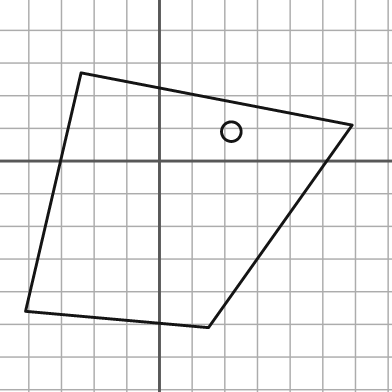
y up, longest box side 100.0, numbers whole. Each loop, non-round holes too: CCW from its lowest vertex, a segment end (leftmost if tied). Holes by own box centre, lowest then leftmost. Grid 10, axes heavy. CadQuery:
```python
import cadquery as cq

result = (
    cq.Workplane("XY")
    .moveTo(15.0, -51.0)
    .lineTo(59.0, 11.0)
    .lineTo(-24.0, 27.0)
    .lineTo(-41.0, -46.0)
    .close()
    .moveTo(22.0, 9.0)
    .circle(3.0)
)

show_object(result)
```